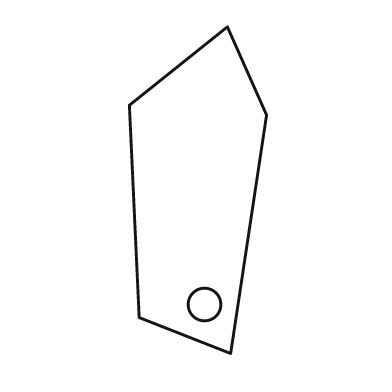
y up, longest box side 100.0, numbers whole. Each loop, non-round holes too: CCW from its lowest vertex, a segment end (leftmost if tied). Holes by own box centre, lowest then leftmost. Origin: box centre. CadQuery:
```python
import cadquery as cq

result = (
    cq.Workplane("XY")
    .moveTo(10.0, -50.0)
    .lineTo(21.0, 23.0)
    .lineTo(9.0, 50.0)
    .lineTo(-21.0, 26.0)
    .lineTo(-18.0, -39.0)
    .close()
    .moveTo(2.0, -35.0)
    .circle(5.0)
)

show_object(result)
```